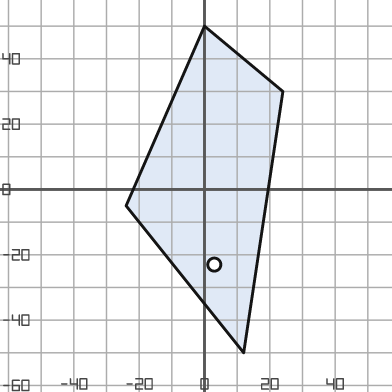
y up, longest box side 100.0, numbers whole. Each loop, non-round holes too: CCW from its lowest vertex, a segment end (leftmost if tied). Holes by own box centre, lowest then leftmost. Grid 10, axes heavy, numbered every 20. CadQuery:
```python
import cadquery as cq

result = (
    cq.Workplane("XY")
    .moveTo(12.0, -50.0)
    .lineTo(24.0, 30.0)
    .lineTo(0.0, 50.0)
    .lineTo(-24.0, -5.0)
    .close()
    .moveTo(3.0, -23.0)
    .circle(2.0)
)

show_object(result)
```